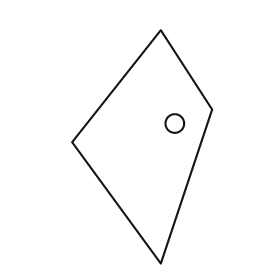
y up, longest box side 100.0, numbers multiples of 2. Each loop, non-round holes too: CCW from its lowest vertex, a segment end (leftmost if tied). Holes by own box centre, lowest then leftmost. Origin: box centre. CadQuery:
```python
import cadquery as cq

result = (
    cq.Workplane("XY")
    .moveTo(8.0, -50.0)
    .lineTo(30.0, 16.0)
    .lineTo(8.0, 50.0)
    .lineTo(-30.0, 2.0)
    .close()
    .moveTo(14.0, 10.0)
    .circle(4.0)
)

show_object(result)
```